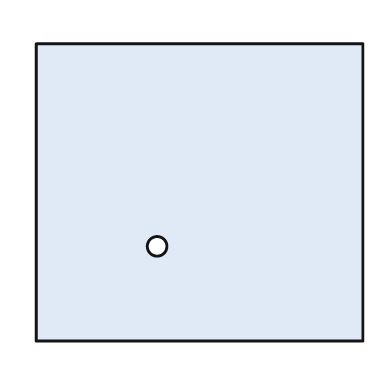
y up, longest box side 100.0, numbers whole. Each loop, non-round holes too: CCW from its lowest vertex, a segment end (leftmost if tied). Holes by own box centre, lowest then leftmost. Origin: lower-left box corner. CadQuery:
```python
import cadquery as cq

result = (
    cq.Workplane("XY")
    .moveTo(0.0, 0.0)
    .lineTo(100.0, 0.0)
    .lineTo(100.0, 91.0)
    .lineTo(0.0, 91.0)
    .close()
    .moveTo(37.0, 29.0)
    .circle(3.0)
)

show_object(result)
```